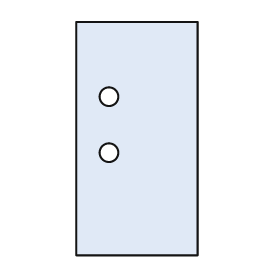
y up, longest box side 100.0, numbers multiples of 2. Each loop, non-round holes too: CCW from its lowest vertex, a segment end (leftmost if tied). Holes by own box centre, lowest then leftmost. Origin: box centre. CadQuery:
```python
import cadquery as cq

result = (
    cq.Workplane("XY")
    .moveTo(-26.0, -50.0)
    .lineTo(26.0, -50.0)
    .lineTo(26.0, 50.0)
    .lineTo(-26.0, 50.0)
    .close()
    .moveTo(-12.0, -6.0)
    .circle(4.0)
    .moveTo(-12.0, 18.0)
    .circle(4.0)
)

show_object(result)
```